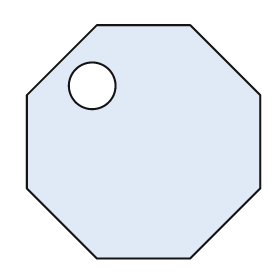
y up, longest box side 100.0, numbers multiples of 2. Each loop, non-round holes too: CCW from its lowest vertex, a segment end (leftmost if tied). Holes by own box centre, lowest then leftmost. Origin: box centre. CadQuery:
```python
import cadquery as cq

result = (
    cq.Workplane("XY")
    .moveTo(-20.0, -50.0)
    .lineTo(20.0, -50.0)
    .lineTo(50.0, -20.0)
    .lineTo(50.0, 20.0)
    .lineTo(20.0, 50.0)
    .lineTo(-20.0, 50.0)
    .lineTo(-50.0, 20.0)
    .lineTo(-50.0, -20.0)
    .close()
    .moveTo(-22.0, 24.0)
    .circle(10.0)
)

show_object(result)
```